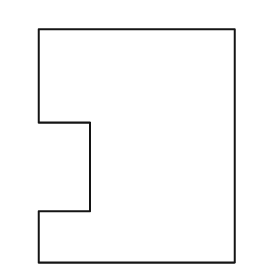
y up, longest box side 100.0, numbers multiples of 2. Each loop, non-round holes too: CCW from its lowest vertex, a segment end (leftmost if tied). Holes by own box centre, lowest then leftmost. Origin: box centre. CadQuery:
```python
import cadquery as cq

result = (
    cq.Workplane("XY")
    .moveTo(-42.0, -50.0)
    .lineTo(42.0, -50.0)
    .lineTo(42.0, 50.0)
    .lineTo(-42.0, 50.0)
    .lineTo(-42.0, 10.0)
    .lineTo(-20.0, 10.0)
    .lineTo(-20.0, -28.0)
    .lineTo(-42.0, -28.0)
    .close()
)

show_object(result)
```